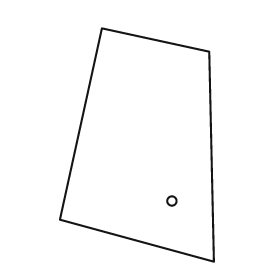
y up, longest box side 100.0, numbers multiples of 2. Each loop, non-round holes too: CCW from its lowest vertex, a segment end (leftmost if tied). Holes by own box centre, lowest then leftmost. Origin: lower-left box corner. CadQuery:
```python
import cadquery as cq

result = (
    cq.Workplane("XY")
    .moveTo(66.0, 0.0)
    .lineTo(64.0, 90.0)
    .lineTo(18.0, 100.0)
    .lineTo(0.0, 18.0)
    .close()
    .moveTo(48.0, 26.0)
    .circle(2.0)
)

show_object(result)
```